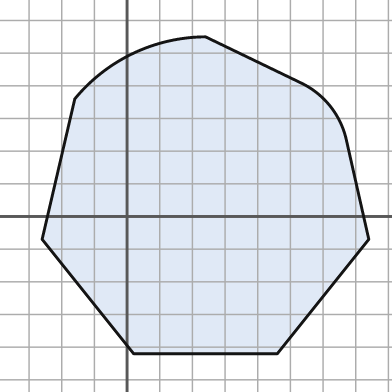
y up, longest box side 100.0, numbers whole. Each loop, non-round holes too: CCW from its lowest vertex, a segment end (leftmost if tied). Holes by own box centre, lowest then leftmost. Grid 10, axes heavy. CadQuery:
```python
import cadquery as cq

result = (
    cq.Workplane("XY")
    .moveTo(2.0, -42.0)
    .lineTo(46.0, -42.0)
    .lineTo(74.0, -7.0)
    .lineTo(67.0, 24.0)
    .threePointArc((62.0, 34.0), (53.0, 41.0))
    .lineTo(24.0, 55.0)
    .threePointArc((2.0, 50.0), (-16.0, 36.0))
    .lineTo(-26.0, -7.0)
    .close()
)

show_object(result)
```